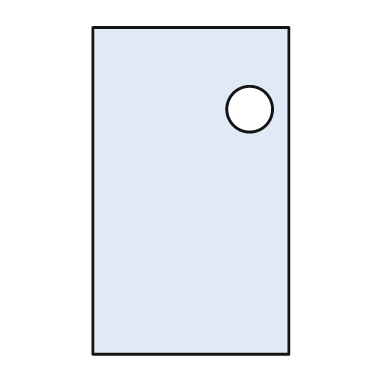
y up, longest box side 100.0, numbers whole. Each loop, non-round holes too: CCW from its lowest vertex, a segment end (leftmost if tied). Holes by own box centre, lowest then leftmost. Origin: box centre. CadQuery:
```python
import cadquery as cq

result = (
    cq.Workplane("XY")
    .moveTo(-30.0, -50.0)
    .lineTo(30.0, -50.0)
    .lineTo(30.0, 50.0)
    .lineTo(-30.0, 50.0)
    .close()
    .moveTo(18.0, 25.0)
    .circle(7.0)
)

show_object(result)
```